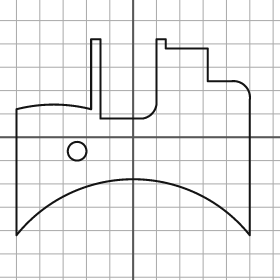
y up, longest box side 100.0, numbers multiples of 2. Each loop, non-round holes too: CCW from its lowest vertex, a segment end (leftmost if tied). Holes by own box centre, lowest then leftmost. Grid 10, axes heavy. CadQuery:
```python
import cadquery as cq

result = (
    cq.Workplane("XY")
    .moveTo(-50.0, -42.0)
    .threePointArc((0.0, -18.0), (50.0, -42.0))
    .lineTo(50.0, 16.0)
    .threePointArc((48.0, 22.0), (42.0, 24.0))
    .lineTo(32.0, 24.0)
    .lineTo(32.0, 38.0)
    .lineTo(14.0, 38.0)
    .lineTo(14.0, 42.0)
    .lineTo(10.0, 42.0)
    .lineTo(10.0, 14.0)
    .threePointArc((8.0, 10.0), (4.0, 8.0))
    .lineTo(-14.0, 8.0)
    .lineTo(-14.0, 42.0)
    .lineTo(-18.0, 42.0)
    .lineTo(-18.0, 12.0)
    .threePointArc((-34.0, 14.0), (-50.0, 12.0))
    .close()
    .moveTo(-24.0, -6.0)
    .circle(4.0)
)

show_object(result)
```